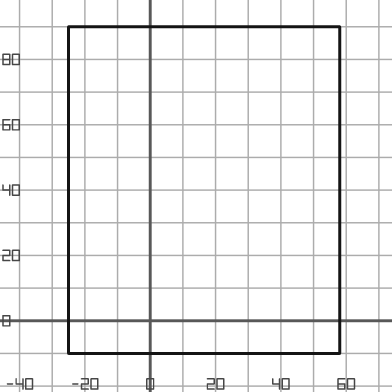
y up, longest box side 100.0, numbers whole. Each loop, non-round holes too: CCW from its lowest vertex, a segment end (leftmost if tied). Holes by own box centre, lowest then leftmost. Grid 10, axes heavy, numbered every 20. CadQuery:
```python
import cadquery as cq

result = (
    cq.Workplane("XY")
    .moveTo(-25.0, -10.0)
    .lineTo(58.0, -10.0)
    .lineTo(58.0, 90.0)
    .lineTo(-25.0, 90.0)
    .close()
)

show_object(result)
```